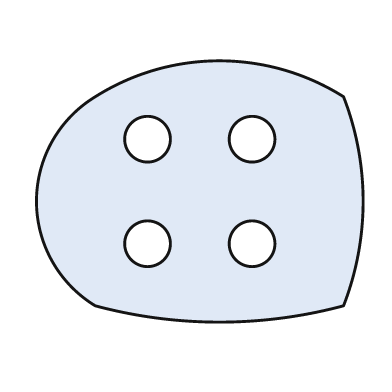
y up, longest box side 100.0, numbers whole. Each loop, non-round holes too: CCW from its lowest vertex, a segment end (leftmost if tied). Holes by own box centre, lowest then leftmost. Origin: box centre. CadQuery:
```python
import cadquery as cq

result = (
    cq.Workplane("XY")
    .moveTo(-32.0, -35.0)
    .threePointArc((6.0, -40.0), (44.0, -35.0))
    .threePointArc((50.0, -3.0), (44.0, 29.0))
    .threePointArc((6.0, 40.0), (-32.0, 29.0))
    .threePointArc((-50.0, -3.0), (-32.0, -35.0))
    .close()
    .moveTo(-16.0, -16.0)
    .circle(7.0)
    .moveTo(16.0, -16.0)
    .circle(7.0)
    .moveTo(-16.0, 16.0)
    .circle(7.0)
    .moveTo(16.0, 16.0)
    .circle(7.0)
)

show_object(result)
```